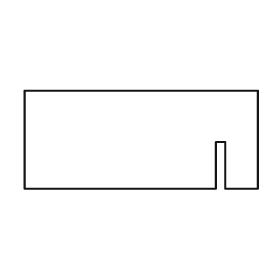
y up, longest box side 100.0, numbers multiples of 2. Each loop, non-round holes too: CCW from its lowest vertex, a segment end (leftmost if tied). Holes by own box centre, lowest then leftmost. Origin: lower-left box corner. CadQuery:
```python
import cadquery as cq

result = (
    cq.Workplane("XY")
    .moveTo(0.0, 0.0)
    .lineTo(82.0, 0.0)
    .lineTo(82.0, 20.0)
    .lineTo(86.0, 20.0)
    .lineTo(86.0, 0.0)
    .lineTo(100.0, 0.0)
    .lineTo(100.0, 42.0)
    .lineTo(0.0, 42.0)
    .close()
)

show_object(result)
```